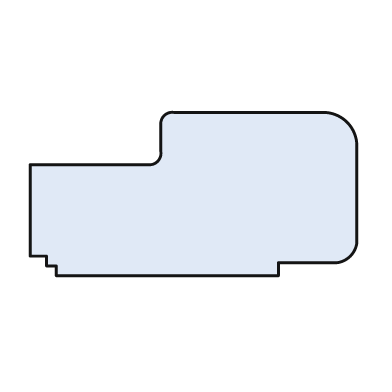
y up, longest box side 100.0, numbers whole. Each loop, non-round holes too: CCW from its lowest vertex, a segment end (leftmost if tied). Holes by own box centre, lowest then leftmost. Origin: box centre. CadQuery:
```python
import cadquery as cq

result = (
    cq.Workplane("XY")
    .moveTo(-42.0, -25.0)
    .lineTo(26.0, -25.0)
    .lineTo(26.0, -21.0)
    .lineTo(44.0, -21.0)
    .threePointArc((48.0, -19.0), (50.0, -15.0))
    .lineTo(50.0, 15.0)
    .threePointArc((47.0, 22.0), (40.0, 25.0))
    .lineTo(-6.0, 25.0)
    .threePointArc((-9.0, 24.0), (-10.0, 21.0))
    .lineTo(-10.0, 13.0)
    .threePointArc((-11.0, 10.0), (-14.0, 9.0))
    .lineTo(-50.0, 9.0)
    .lineTo(-50.0, -19.0)
    .lineTo(-45.0, -19.0)
    .lineTo(-45.0, -22.0)
    .lineTo(-42.0, -22.0)
    .close()
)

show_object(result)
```